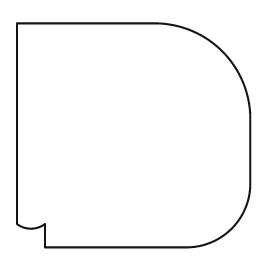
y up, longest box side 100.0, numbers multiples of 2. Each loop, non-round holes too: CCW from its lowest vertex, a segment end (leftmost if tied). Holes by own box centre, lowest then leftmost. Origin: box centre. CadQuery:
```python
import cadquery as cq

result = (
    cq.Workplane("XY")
    .moveTo(-38.0, -48.0)
    .lineTo(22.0, -48.0)
    .threePointArc((42.0, -40.0), (50.0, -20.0))
    .lineTo(50.0, 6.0)
    .threePointArc((38.0, 36.0), (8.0, 48.0))
    .lineTo(-50.0, 48.0)
    .lineTo(-50.0, -38.0)
    .threePointArc((-44.0, -40.0), (-38.0, -38.0))
    .close()
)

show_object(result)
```